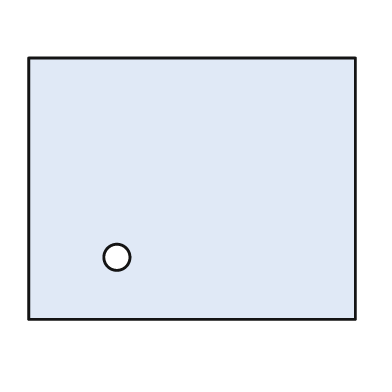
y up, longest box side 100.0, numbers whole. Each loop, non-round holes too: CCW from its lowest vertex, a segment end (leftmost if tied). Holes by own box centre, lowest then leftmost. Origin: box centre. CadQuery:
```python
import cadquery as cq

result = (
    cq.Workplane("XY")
    .moveTo(-50.0, -40.0)
    .lineTo(50.0, -40.0)
    .lineTo(50.0, 40.0)
    .lineTo(-50.0, 40.0)
    .close()
    .moveTo(-23.0, -21.0)
    .circle(4.0)
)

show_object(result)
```